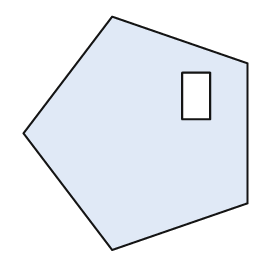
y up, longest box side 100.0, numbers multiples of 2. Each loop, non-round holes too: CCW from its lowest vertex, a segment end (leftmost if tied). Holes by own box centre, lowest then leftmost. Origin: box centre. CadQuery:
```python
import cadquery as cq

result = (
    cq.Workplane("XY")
    .moveTo(-10.0, -50.0)
    .lineTo(48.0, -30.0)
    .lineTo(48.0, 30.0)
    .lineTo(-10.0, 50.0)
    .lineTo(-48.0, 0.0)
    .close()
    .moveTo(20.0, 6.0)
    .lineTo(32.0, 6.0)
    .lineTo(32.0, 26.0)
    .lineTo(20.0, 26.0)
    .close()
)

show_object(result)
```